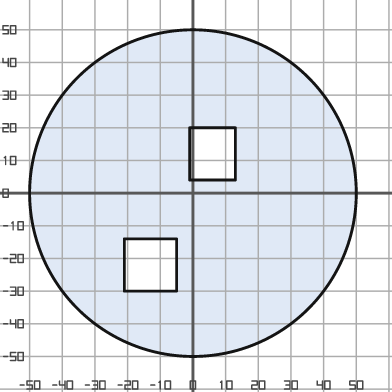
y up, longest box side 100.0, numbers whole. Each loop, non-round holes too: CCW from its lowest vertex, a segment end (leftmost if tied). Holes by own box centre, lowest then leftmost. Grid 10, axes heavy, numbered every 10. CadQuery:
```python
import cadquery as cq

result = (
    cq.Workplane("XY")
    .moveTo(0.0, 0.0)
    .circle(50.0)
    .moveTo(-21.0, -30.0)
    .lineTo(-5.0, -30.0)
    .lineTo(-5.0, -14.0)
    .lineTo(-21.0, -14.0)
    .close()
    .moveTo(-1.0, 4.0)
    .lineTo(13.0, 4.0)
    .lineTo(13.0, 20.0)
    .lineTo(-1.0, 20.0)
    .close()
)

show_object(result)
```